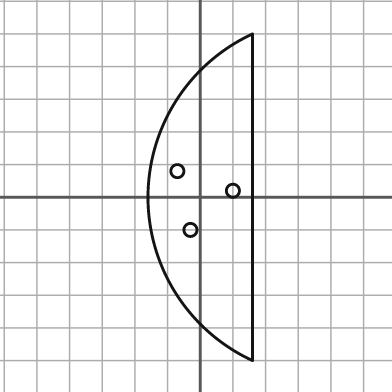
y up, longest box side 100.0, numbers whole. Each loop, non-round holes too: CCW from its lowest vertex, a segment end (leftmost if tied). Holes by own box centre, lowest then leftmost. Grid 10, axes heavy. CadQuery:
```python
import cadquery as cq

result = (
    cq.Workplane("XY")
    .moveTo(16.0, -50.0)
    .lineTo(16.0, 50.0)
    .threePointArc((-16.0, 0.0), (16.0, -50.0))
    .close()
    .moveTo(-3.0, -10.0)
    .circle(2.0)
    .moveTo(10.0, 2.0)
    .circle(2.0)
    .moveTo(-7.0, 8.0)
    .circle(2.0)
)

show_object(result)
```